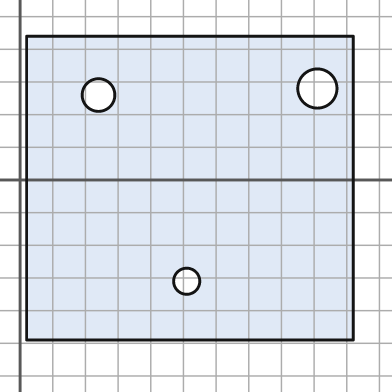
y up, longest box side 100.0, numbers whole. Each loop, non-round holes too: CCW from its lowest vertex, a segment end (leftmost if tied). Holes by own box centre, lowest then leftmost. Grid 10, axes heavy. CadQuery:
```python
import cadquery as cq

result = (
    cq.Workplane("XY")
    .moveTo(2.0, -49.0)
    .lineTo(102.0, -49.0)
    .lineTo(102.0, 44.0)
    .lineTo(2.0, 44.0)
    .close()
    .moveTo(51.0, -31.0)
    .circle(4.0)
    .moveTo(24.0, 26.0)
    .circle(5.0)
    .moveTo(91.0, 28.0)
    .circle(6.0)
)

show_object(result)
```